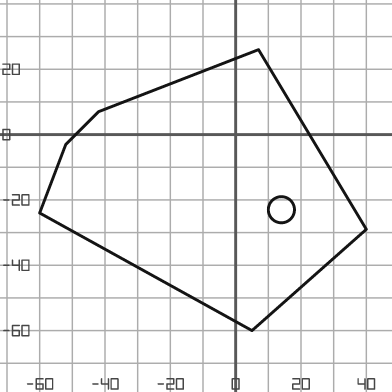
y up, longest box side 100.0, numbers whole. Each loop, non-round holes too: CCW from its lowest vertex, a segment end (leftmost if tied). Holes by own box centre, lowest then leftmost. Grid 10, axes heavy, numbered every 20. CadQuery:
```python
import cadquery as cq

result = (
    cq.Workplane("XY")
    .moveTo(5.0, -60.0)
    .lineTo(40.0, -29.0)
    .lineTo(7.0, 26.0)
    .lineTo(-42.0, 7.0)
    .lineTo(-52.0, -3.0)
    .lineTo(-60.0, -24.0)
    .close()
    .moveTo(14.0, -23.0)
    .circle(4.0)
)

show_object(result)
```